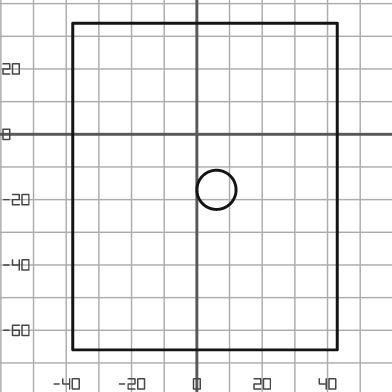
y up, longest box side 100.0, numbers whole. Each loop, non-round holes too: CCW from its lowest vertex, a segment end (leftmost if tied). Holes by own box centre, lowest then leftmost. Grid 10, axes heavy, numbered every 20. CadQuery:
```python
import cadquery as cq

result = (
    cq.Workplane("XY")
    .moveTo(-38.0, -66.0)
    .lineTo(43.0, -66.0)
    .lineTo(43.0, 34.0)
    .lineTo(-38.0, 34.0)
    .close()
    .moveTo(6.0, -17.0)
    .circle(6.0)
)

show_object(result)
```